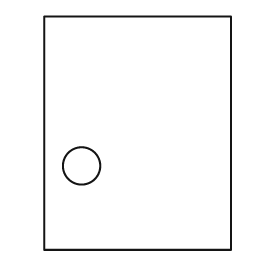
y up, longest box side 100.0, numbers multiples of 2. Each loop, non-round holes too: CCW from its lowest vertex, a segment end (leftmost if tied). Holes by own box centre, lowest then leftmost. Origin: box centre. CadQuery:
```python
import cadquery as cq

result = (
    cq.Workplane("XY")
    .moveTo(-40.0, -50.0)
    .lineTo(40.0, -50.0)
    .lineTo(40.0, 50.0)
    .lineTo(-40.0, 50.0)
    .close()
    .moveTo(-24.0, -14.0)
    .circle(8.0)
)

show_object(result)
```